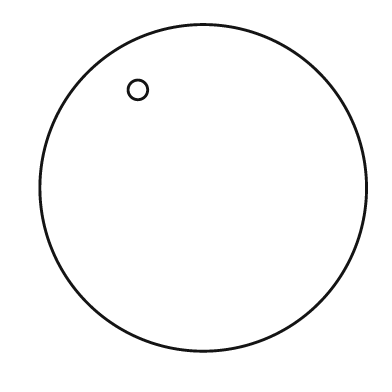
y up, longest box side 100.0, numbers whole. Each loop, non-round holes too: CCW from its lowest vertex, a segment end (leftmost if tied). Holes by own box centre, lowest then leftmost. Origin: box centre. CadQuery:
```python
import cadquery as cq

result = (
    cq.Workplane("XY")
    .moveTo(0.0, 0.0)
    .circle(50.0)
    .moveTo(-20.0, 30.0)
    .circle(3.0)
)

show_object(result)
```